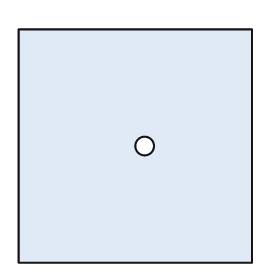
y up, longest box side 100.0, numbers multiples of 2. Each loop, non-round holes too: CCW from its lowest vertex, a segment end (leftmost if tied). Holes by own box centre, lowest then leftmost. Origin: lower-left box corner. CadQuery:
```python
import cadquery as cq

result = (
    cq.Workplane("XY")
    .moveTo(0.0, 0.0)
    .lineTo(100.0, 0.0)
    .lineTo(100.0, 100.0)
    .lineTo(0.0, 100.0)
    .close()
    .moveTo(54.0, 50.0)
    .circle(4.0)
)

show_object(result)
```